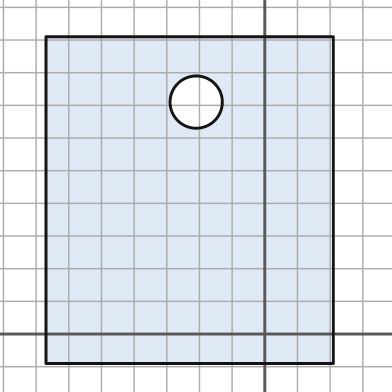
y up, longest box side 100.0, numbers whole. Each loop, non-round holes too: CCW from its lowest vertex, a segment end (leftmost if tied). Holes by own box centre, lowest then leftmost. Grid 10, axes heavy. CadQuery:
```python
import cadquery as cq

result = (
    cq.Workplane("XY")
    .moveTo(-67.0, -9.0)
    .lineTo(21.0, -9.0)
    .lineTo(21.0, 91.0)
    .lineTo(-67.0, 91.0)
    .close()
    .moveTo(-21.0, 71.0)
    .circle(8.0)
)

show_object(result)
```